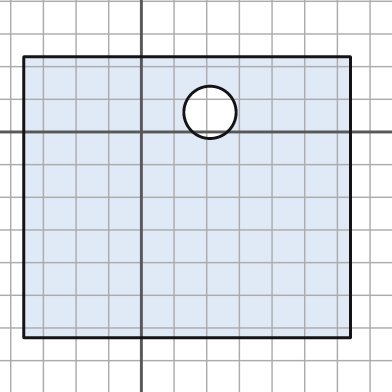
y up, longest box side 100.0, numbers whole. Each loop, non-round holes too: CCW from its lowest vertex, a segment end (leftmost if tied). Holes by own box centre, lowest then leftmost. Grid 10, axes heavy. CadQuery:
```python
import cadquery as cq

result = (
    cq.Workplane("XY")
    .moveTo(-36.0, -63.0)
    .lineTo(64.0, -63.0)
    .lineTo(64.0, 23.0)
    .lineTo(-36.0, 23.0)
    .close()
    .moveTo(21.0, 6.0)
    .circle(8.0)
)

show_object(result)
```